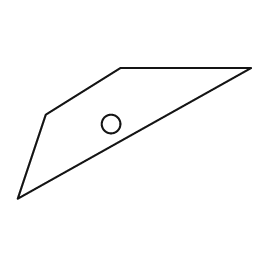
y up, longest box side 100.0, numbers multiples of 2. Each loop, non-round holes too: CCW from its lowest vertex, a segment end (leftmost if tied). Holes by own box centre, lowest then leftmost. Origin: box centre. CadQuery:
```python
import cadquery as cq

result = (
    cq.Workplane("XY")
    .moveTo(-50.0, -28.0)
    .lineTo(50.0, 28.0)
    .lineTo(-6.0, 28.0)
    .lineTo(-38.0, 8.0)
    .close()
    .moveTo(-10.0, 4.0)
    .circle(4.0)
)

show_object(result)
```